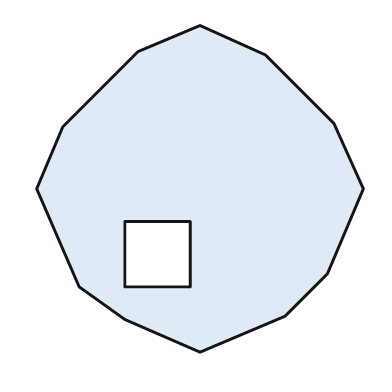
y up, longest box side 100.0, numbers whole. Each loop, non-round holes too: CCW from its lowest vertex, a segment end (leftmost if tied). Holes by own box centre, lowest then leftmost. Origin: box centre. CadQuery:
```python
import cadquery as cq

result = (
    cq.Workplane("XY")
    .moveTo(0.0, -50.0)
    .lineTo(26.0, -39.0)
    .lineTo(39.0, -26.0)
    .lineTo(50.0, 0.0)
    .lineTo(41.0, 20.0)
    .lineTo(20.0, 41.0)
    .lineTo(0.0, 50.0)
    .lineTo(-19.0, 42.0)
    .lineTo(-42.0, 19.0)
    .lineTo(-50.0, 0.0)
    .lineTo(-37.0, -30.0)
    .lineTo(-23.0, -40.0)
    .close()
    .moveTo(-23.0, -30.0)
    .lineTo(-3.0, -30.0)
    .lineTo(-3.0, -10.0)
    .lineTo(-23.0, -10.0)
    .close()
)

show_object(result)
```